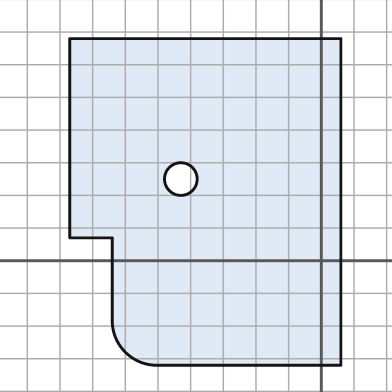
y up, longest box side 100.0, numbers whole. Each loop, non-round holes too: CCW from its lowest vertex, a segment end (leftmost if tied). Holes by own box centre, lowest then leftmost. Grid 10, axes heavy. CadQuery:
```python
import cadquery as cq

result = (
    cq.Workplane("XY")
    .moveTo(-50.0, -32.0)
    .lineTo(6.0, -32.0)
    .lineTo(6.0, 68.0)
    .lineTo(-77.0, 68.0)
    .lineTo(-77.0, 7.0)
    .lineTo(-64.0, 7.0)
    .lineTo(-64.0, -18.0)
    .threePointArc((-60.0, -28.0), (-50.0, -32.0))
    .close()
    .moveTo(-43.0, 25.0)
    .circle(5.0)
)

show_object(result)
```